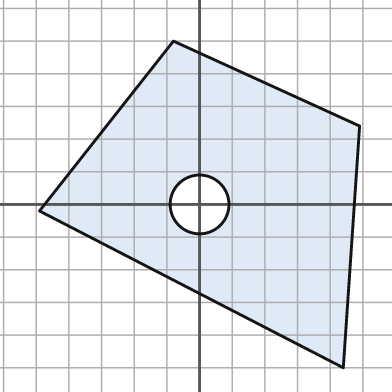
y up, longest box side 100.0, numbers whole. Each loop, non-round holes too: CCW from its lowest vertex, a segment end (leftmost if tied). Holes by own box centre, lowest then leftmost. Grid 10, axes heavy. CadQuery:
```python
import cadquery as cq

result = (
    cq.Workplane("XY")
    .moveTo(44.0, -50.0)
    .lineTo(49.0, 24.0)
    .lineTo(-8.0, 50.0)
    .lineTo(-49.0, -2.0)
    .close()
    .moveTo(0.0, 0.0)
    .circle(9.0)
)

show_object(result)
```